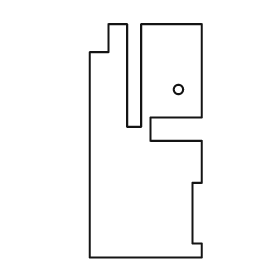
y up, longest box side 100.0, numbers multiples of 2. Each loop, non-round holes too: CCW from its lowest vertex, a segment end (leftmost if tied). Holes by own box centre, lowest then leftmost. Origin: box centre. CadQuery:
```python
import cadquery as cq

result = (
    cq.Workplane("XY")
    .moveTo(-24.0, -50.0)
    .lineTo(24.0, -50.0)
    .lineTo(24.0, -44.0)
    .lineTo(20.0, -44.0)
    .lineTo(20.0, -18.0)
    .lineTo(24.0, -18.0)
    .lineTo(24.0, 0.0)
    .lineTo(2.0, 0.0)
    .lineTo(2.0, 10.0)
    .lineTo(24.0, 10.0)
    .lineTo(24.0, 50.0)
    .lineTo(-2.0, 50.0)
    .lineTo(-2.0, 6.0)
    .lineTo(-8.0, 6.0)
    .lineTo(-8.0, 50.0)
    .lineTo(-16.0, 50.0)
    .lineTo(-16.0, 38.0)
    .lineTo(-24.0, 38.0)
    .close()
    .moveTo(14.0, 22.0)
    .circle(2.0)
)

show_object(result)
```